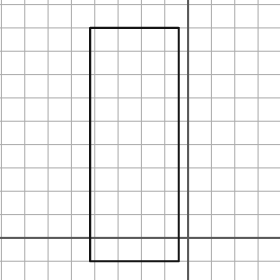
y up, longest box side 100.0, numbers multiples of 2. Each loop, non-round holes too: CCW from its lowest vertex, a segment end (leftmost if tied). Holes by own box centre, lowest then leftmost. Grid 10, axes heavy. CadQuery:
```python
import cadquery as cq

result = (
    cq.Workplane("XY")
    .moveTo(-42.0, -10.0)
    .lineTo(-4.0, -10.0)
    .lineTo(-4.0, 90.0)
    .lineTo(-42.0, 90.0)
    .close()
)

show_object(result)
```